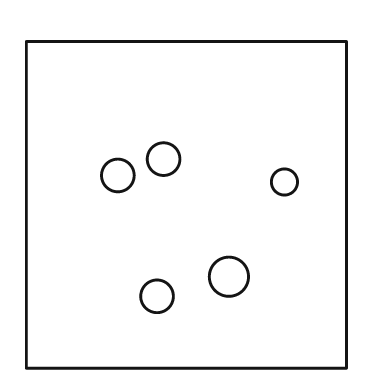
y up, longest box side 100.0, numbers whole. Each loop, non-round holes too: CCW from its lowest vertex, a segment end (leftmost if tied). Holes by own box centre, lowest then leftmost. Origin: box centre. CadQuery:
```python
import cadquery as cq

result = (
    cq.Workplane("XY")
    .moveTo(-49.0, -50.0)
    .lineTo(49.0, -50.0)
    .lineTo(49.0, 50.0)
    .lineTo(-49.0, 50.0)
    .close()
    .moveTo(-9.0, -28.0)
    .circle(5.0)
    .moveTo(13.0, -22.0)
    .circle(6.0)
    .moveTo(30.0, 7.0)
    .circle(4.0)
    .moveTo(-21.0, 9.0)
    .circle(5.0)
    .moveTo(-7.0, 14.0)
    .circle(5.0)
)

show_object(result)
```